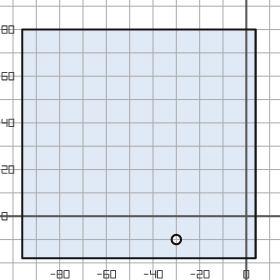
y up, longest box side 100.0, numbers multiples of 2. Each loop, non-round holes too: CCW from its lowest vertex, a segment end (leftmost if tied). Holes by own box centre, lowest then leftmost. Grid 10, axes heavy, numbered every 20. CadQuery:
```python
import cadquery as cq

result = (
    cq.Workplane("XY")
    .moveTo(-96.0, -18.0)
    .lineTo(4.0, -18.0)
    .lineTo(4.0, 80.0)
    .lineTo(-96.0, 80.0)
    .close()
    .moveTo(-30.0, -10.0)
    .circle(2.0)
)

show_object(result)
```